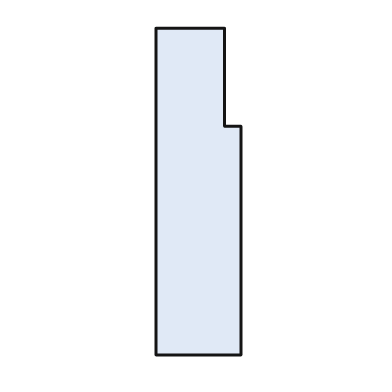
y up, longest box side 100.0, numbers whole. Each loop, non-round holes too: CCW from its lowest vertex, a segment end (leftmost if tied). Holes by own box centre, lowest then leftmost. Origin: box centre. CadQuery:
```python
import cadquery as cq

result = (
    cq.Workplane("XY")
    .moveTo(-13.0, -50.0)
    .lineTo(13.0, -50.0)
    .lineTo(13.0, 20.0)
    .lineTo(8.0, 20.0)
    .lineTo(8.0, 50.0)
    .lineTo(-13.0, 50.0)
    .close()
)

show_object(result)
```